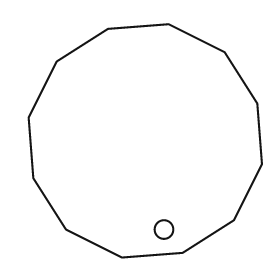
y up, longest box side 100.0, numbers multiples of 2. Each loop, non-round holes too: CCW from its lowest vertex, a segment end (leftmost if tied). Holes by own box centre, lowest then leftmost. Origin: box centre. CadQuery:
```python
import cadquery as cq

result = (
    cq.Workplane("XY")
    .moveTo(-10.0, -50.0)
    .lineTo(16.0, -48.0)
    .lineTo(38.0, -34.0)
    .lineTo(50.0, -10.0)
    .lineTo(48.0, 16.0)
    .lineTo(34.0, 38.0)
    .lineTo(10.0, 50.0)
    .lineTo(-16.0, 48.0)
    .lineTo(-38.0, 34.0)
    .lineTo(-50.0, 10.0)
    .lineTo(-48.0, -16.0)
    .lineTo(-34.0, -38.0)
    .close()
    .moveTo(8.0, -38.0)
    .circle(4.0)
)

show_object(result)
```